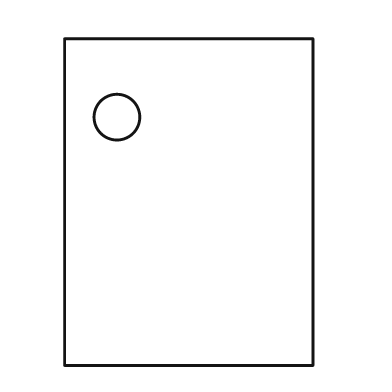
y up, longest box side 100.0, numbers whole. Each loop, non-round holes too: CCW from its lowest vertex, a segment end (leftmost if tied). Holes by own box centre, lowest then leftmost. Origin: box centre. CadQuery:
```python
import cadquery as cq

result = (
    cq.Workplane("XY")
    .moveTo(-38.0, -50.0)
    .lineTo(38.0, -50.0)
    .lineTo(38.0, 50.0)
    .lineTo(-38.0, 50.0)
    .close()
    .moveTo(-22.0, 26.0)
    .circle(7.0)
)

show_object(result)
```